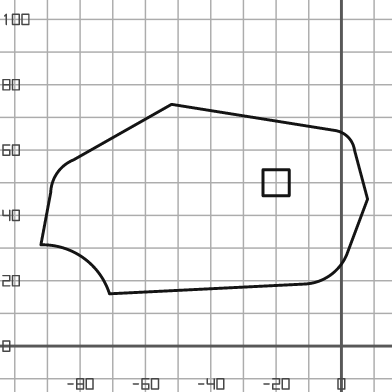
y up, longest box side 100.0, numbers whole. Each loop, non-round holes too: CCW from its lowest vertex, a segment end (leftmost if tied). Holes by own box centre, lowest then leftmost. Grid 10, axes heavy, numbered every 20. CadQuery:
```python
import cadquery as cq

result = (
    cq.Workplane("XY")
    .moveTo(-71.0, 16.0)
    .lineTo(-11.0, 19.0)
    .threePointArc((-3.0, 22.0), (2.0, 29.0))
    .lineTo(8.0, 45.0)
    .lineTo(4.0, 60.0)
    .threePointArc((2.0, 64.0), (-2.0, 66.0))
    .lineTo(-52.0, 74.0)
    .lineTo(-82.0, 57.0)
    .threePointArc((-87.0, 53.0), (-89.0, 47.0))
    .lineTo(-92.0, 31.0)
    .threePointArc((-79.0, 27.0), (-71.0, 16.0))
    .close()
    .moveTo(-24.0, 46.0)
    .lineTo(-16.0, 46.0)
    .lineTo(-16.0, 54.0)
    .lineTo(-24.0, 54.0)
    .close()
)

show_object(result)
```